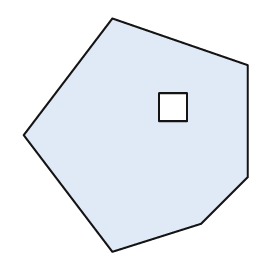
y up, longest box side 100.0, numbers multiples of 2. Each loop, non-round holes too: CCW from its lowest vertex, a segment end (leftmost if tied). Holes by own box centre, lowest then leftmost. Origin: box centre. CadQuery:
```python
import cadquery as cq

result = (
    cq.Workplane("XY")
    .moveTo(-10.0, -50.0)
    .lineTo(28.0, -38.0)
    .lineTo(48.0, -18.0)
    .lineTo(48.0, 30.0)
    .lineTo(-10.0, 50.0)
    .lineTo(-48.0, 0.0)
    .close()
    .moveTo(10.0, 6.0)
    .lineTo(22.0, 6.0)
    .lineTo(22.0, 18.0)
    .lineTo(10.0, 18.0)
    .close()
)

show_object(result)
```